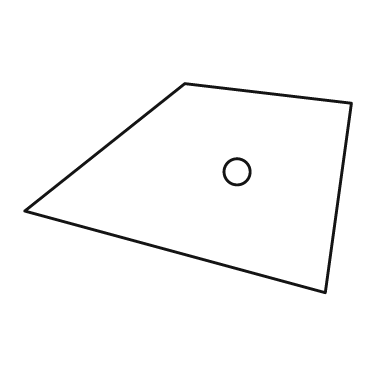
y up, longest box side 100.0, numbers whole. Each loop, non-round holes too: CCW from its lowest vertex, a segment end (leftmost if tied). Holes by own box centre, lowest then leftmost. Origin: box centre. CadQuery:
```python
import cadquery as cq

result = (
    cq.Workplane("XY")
    .moveTo(42.0, -32.0)
    .lineTo(50.0, 26.0)
    .lineTo(-1.0, 32.0)
    .lineTo(-50.0, -7.0)
    .close()
    .moveTo(15.0, 5.0)
    .circle(4.0)
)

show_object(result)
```